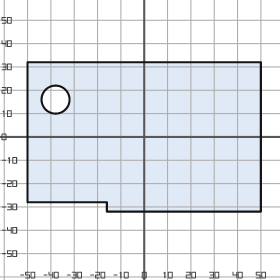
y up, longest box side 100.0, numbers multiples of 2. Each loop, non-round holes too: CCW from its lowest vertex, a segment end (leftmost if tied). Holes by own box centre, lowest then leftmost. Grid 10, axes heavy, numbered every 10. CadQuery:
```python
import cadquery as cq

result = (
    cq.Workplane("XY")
    .moveTo(-16.0, -32.0)
    .lineTo(50.0, -32.0)
    .lineTo(50.0, 32.0)
    .lineTo(-50.0, 32.0)
    .lineTo(-50.0, -28.0)
    .lineTo(-16.0, -28.0)
    .close()
    .moveTo(-38.0, 16.0)
    .circle(6.0)
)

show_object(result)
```